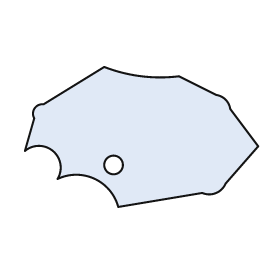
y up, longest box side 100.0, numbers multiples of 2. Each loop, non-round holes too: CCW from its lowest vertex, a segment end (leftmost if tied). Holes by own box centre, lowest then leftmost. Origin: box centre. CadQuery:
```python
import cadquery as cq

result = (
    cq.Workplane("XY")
    .moveTo(-10.0, -30.0)
    .lineTo(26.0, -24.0)
    .threePointArc((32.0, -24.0), (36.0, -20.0))
    .lineTo(50.0, -4.0)
    .lineTo(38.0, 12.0)
    .threePointArc((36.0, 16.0), (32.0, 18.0))
    .lineTo(16.0, 26.0)
    .threePointArc((0.0, 26.0), (-16.0, 30.0))
    .lineTo(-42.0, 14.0)
    .threePointArc((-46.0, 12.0), (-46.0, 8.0))
    .lineTo(-50.0, -6.0)
    .threePointArc((-38.0, -6.0), (-36.0, -18.0))
    .threePointArc((-20.0, -18.0), (-10.0, -30.0))
    .close()
    .moveTo(-12.0, -12.0)
    .circle(4.0)
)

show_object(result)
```